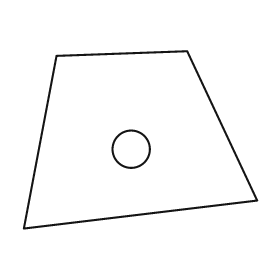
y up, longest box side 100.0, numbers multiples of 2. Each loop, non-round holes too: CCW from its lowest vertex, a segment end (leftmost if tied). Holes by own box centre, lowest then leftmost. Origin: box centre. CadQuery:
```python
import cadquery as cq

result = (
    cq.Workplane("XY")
    .moveTo(-50.0, -38.0)
    .lineTo(50.0, -26.0)
    .lineTo(20.0, 38.0)
    .lineTo(-36.0, 36.0)
    .close()
    .moveTo(-4.0, -4.0)
    .circle(8.0)
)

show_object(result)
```